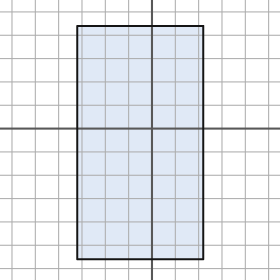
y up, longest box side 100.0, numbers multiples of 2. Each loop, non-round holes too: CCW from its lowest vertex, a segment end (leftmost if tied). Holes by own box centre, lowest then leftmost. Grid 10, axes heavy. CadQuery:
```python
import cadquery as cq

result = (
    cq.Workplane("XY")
    .moveTo(-32.0, -56.0)
    .lineTo(22.0, -56.0)
    .lineTo(22.0, 44.0)
    .lineTo(-32.0, 44.0)
    .close()
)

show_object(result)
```